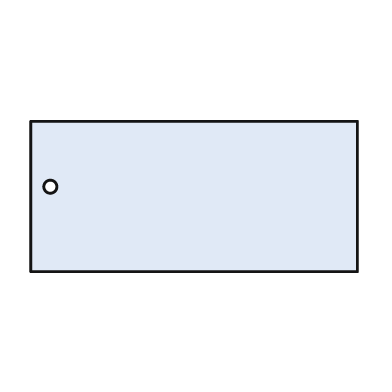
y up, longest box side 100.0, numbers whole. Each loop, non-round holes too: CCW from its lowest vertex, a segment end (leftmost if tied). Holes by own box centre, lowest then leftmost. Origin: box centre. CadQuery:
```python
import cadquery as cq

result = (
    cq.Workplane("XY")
    .moveTo(-50.0, -23.0)
    .lineTo(50.0, -23.0)
    .lineTo(50.0, 23.0)
    .lineTo(-50.0, 23.0)
    .close()
    .moveTo(-44.0, 3.0)
    .circle(2.0)
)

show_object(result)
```